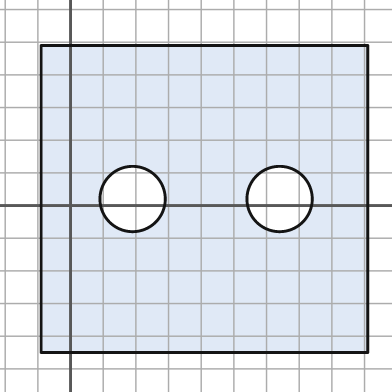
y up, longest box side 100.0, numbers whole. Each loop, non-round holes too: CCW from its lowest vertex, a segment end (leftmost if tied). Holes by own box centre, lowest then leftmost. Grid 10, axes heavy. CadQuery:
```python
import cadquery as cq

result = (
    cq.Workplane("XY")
    .moveTo(-9.0, -45.0)
    .lineTo(91.0, -45.0)
    .lineTo(91.0, 49.0)
    .lineTo(-9.0, 49.0)
    .close()
    .moveTo(19.0, 2.0)
    .circle(10.0)
    .moveTo(64.0, 2.0)
    .circle(10.0)
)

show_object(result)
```